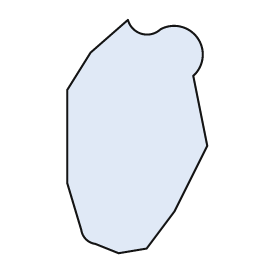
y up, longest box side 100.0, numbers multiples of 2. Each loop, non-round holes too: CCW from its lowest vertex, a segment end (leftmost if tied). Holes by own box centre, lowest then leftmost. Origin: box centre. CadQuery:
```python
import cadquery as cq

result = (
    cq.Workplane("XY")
    .moveTo(-8.0, -50.0)
    .lineTo(4.0, -48.0)
    .lineTo(16.0, -32.0)
    .lineTo(30.0, -4.0)
    .lineTo(24.0, 26.0)
    .threePointArc((26.0, 42.0), (10.0, 46.0))
    .threePointArc((2.0, 44.0), (-4.0, 50.0))
    .lineTo(-20.0, 36.0)
    .lineTo(-30.0, 20.0)
    .lineTo(-30.0, -20.0)
    .lineTo(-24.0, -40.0)
    .threePointArc((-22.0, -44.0), (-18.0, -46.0))
    .close()
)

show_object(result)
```